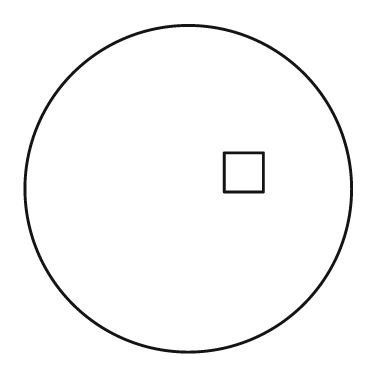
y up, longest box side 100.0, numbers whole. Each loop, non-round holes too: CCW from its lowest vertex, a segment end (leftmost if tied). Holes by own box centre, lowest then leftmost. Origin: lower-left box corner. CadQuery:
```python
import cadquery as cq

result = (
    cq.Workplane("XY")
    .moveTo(50.0, 50.0)
    .circle(50.0)
    .moveTo(61.0, 49.0)
    .lineTo(73.0, 49.0)
    .lineTo(73.0, 61.0)
    .lineTo(61.0, 61.0)
    .close()
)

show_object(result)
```